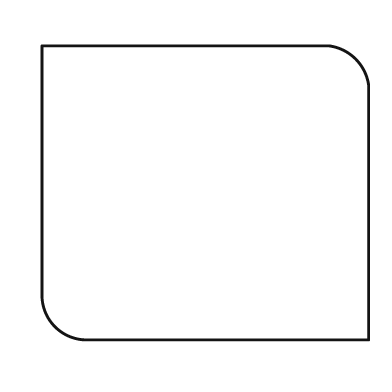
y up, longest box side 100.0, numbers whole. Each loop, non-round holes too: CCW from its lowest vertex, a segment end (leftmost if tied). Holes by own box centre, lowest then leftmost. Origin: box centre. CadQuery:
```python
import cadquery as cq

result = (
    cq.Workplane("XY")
    .moveTo(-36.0, -45.0)
    .lineTo(50.0, -45.0)
    .lineTo(50.0, 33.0)
    .threePointArc((46.0, 41.0), (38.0, 45.0))
    .lineTo(-50.0, 45.0)
    .lineTo(-50.0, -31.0)
    .threePointArc((-46.0, -41.0), (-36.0, -45.0))
    .close()
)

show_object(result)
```